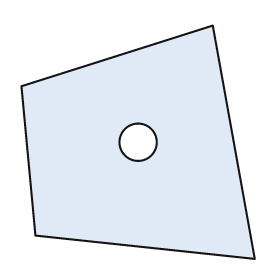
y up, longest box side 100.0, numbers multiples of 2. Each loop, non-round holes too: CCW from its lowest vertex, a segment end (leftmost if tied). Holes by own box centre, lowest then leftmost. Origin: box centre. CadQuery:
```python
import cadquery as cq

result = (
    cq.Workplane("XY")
    .moveTo(50.0, -50.0)
    .lineTo(32.0, 50.0)
    .lineTo(-50.0, 24.0)
    .lineTo(-44.0, -40.0)
    .close()
    .moveTo(0.0, 0.0)
    .circle(8.0)
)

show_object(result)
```